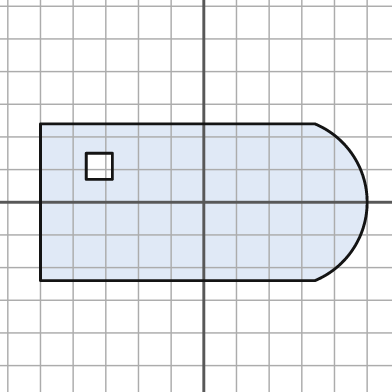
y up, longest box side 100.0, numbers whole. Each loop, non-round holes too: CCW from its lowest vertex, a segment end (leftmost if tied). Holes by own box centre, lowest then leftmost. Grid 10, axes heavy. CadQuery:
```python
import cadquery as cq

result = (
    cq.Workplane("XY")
    .moveTo(-50.0, -24.0)
    .lineTo(34.0, -24.0)
    .threePointArc((50.0, 0.0), (34.0, 24.0))
    .lineTo(-50.0, 24.0)
    .close()
    .moveTo(-36.0, 7.0)
    .lineTo(-28.0, 7.0)
    .lineTo(-28.0, 15.0)
    .lineTo(-36.0, 15.0)
    .close()
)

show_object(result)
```